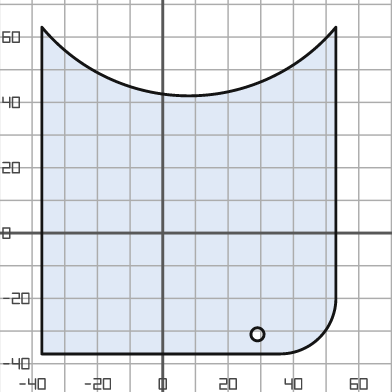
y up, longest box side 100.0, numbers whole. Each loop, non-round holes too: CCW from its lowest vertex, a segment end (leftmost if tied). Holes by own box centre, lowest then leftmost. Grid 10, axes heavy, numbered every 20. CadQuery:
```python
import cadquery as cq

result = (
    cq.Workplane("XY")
    .moveTo(-37.0, -37.0)
    .lineTo(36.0, -37.0)
    .threePointArc((48.0, -32.0), (53.0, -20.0))
    .lineTo(53.0, 63.0)
    .threePointArc((8.0, 42.0), (-37.0, 63.0))
    .close()
    .moveTo(29.0, -31.0)
    .circle(2.0)
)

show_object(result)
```